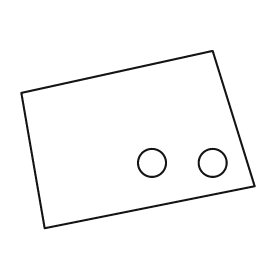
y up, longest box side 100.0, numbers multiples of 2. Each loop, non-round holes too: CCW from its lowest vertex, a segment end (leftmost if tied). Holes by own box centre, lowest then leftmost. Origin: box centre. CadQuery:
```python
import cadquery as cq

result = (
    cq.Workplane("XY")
    .moveTo(-40.0, -38.0)
    .lineTo(50.0, -20.0)
    .lineTo(32.0, 38.0)
    .lineTo(-50.0, 20.0)
    .close()
    .moveTo(6.0, -10.0)
    .circle(6.0)
    .moveTo(32.0, -10.0)
    .circle(6.0)
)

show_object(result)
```